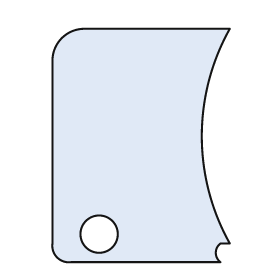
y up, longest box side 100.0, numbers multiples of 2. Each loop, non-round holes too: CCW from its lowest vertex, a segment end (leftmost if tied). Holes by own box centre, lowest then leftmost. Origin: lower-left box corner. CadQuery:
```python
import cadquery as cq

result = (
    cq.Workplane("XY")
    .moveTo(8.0, 0.0)
    .lineTo(72.0, 0.0)
    .threePointArc((70.0, 4.0), (72.0, 8.0))
    .lineTo(76.0, 8.0)
    .threePointArc((64.0, 54.0), (76.0, 100.0))
    .lineTo(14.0, 100.0)
    .threePointArc((4.0, 96.0), (0.0, 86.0))
    .lineTo(0.0, 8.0)
    .threePointArc((2.0, 2.0), (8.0, 0.0))
    .close()
    .moveTo(20.0, 12.0)
    .circle(8.0)
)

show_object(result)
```